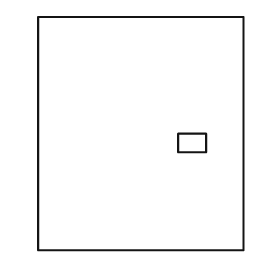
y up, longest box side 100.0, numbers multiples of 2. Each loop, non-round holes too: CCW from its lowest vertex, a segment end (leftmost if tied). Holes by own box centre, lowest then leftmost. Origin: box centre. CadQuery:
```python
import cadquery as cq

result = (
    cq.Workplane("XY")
    .moveTo(-44.0, -50.0)
    .lineTo(44.0, -50.0)
    .lineTo(44.0, 50.0)
    .lineTo(-44.0, 50.0)
    .close()
    .moveTo(16.0, -8.0)
    .lineTo(28.0, -8.0)
    .lineTo(28.0, 0.0)
    .lineTo(16.0, 0.0)
    .close()
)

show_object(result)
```